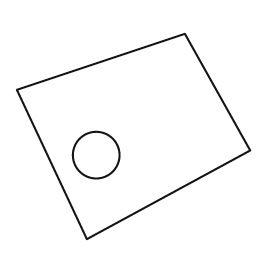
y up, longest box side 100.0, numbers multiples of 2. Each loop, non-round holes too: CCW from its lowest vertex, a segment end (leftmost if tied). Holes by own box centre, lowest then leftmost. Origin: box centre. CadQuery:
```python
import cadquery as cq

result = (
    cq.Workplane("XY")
    .moveTo(-20.0, -44.0)
    .lineTo(50.0, -6.0)
    .lineTo(22.0, 44.0)
    .lineTo(-50.0, 20.0)
    .close()
    .moveTo(-16.0, -8.0)
    .circle(10.0)
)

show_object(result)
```